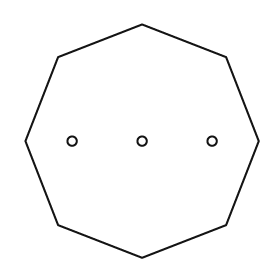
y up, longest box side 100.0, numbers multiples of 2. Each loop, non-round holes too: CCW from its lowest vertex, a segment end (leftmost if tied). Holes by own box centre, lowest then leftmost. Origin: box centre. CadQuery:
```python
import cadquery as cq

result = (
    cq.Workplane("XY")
    .moveTo(0.0, -50.0)
    .lineTo(36.0, -36.0)
    .lineTo(50.0, 0.0)
    .lineTo(36.0, 36.0)
    .lineTo(0.0, 50.0)
    .lineTo(-36.0, 36.0)
    .lineTo(-50.0, 0.0)
    .lineTo(-36.0, -36.0)
    .close()
    .moveTo(-30.0, 0.0)
    .circle(2.0)
    .moveTo(0.0, 0.0)
    .circle(2.0)
    .moveTo(30.0, 0.0)
    .circle(2.0)
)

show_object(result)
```